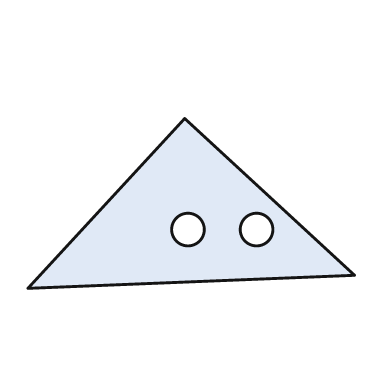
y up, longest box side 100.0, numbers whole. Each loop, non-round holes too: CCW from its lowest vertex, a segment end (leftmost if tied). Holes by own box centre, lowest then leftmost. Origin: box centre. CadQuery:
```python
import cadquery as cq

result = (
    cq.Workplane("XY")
    .moveTo(-50.0, -26.0)
    .lineTo(50.0, -22.0)
    .lineTo(-2.0, 26.0)
    .close()
    .moveTo(-1.0, -8.0)
    .circle(5.0)
    .moveTo(20.0, -8.0)
    .circle(5.0)
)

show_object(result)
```